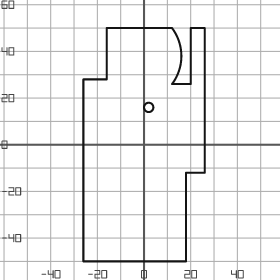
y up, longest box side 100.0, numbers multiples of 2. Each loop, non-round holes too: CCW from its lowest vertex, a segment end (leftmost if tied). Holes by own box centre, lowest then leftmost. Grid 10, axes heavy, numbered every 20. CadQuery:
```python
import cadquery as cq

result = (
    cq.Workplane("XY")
    .moveTo(-26.0, -50.0)
    .lineTo(18.0, -50.0)
    .lineTo(18.0, -12.0)
    .lineTo(26.0, -12.0)
    .lineTo(26.0, 50.0)
    .lineTo(20.0, 50.0)
    .lineTo(20.0, 26.0)
    .lineTo(12.0, 26.0)
    .threePointArc((16.0, 38.0), (12.0, 50.0))
    .lineTo(-16.0, 50.0)
    .lineTo(-16.0, 28.0)
    .lineTo(-26.0, 28.0)
    .close()
    .moveTo(2.0, 16.0)
    .circle(2.0)
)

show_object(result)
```